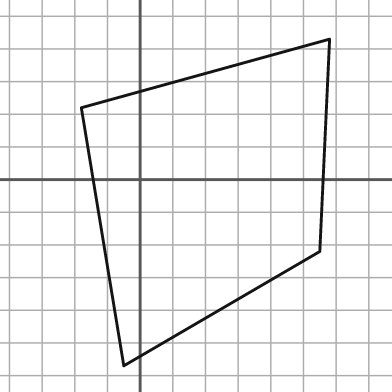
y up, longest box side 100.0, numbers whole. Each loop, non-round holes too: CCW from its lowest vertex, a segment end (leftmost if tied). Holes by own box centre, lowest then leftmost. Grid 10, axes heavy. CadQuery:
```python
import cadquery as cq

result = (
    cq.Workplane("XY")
    .moveTo(-5.0, -57.0)
    .lineTo(55.0, -22.0)
    .lineTo(58.0, 43.0)
    .lineTo(-18.0, 22.0)
    .close()
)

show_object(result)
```